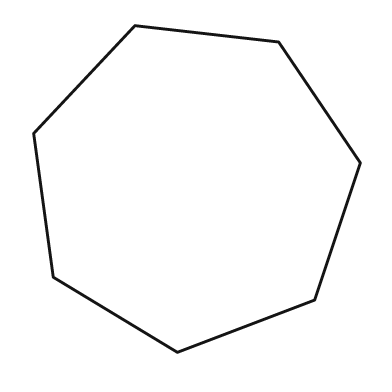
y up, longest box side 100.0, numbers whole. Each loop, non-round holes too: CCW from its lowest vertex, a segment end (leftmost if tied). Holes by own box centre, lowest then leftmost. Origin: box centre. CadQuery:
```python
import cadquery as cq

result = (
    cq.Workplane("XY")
    .moveTo(-6.0, -50.0)
    .lineTo(36.0, -34.0)
    .lineTo(50.0, 8.0)
    .lineTo(25.0, 45.0)
    .lineTo(-19.0, 50.0)
    .lineTo(-50.0, 17.0)
    .lineTo(-44.0, -27.0)
    .close()
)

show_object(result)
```